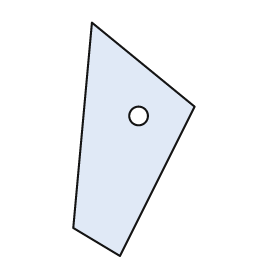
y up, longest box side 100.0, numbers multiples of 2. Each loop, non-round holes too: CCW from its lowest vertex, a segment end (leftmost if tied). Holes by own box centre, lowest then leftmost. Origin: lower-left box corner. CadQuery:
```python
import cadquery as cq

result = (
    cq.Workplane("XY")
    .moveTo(20.0, 0.0)
    .lineTo(52.0, 64.0)
    .lineTo(8.0, 100.0)
    .lineTo(0.0, 12.0)
    .close()
    .moveTo(28.0, 60.0)
    .circle(4.0)
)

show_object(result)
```